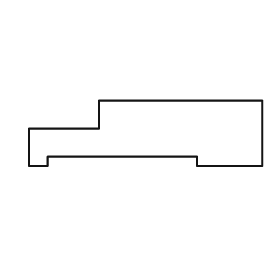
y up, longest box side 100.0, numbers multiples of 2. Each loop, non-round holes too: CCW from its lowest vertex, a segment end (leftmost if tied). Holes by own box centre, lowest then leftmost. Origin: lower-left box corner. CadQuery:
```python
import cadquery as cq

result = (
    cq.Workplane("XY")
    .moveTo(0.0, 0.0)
    .lineTo(8.0, 0.0)
    .lineTo(8.0, 4.0)
    .lineTo(72.0, 4.0)
    .lineTo(72.0, 0.0)
    .lineTo(100.0, 0.0)
    .lineTo(100.0, 28.0)
    .lineTo(30.0, 28.0)
    .lineTo(30.0, 16.0)
    .lineTo(0.0, 16.0)
    .close()
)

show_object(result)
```